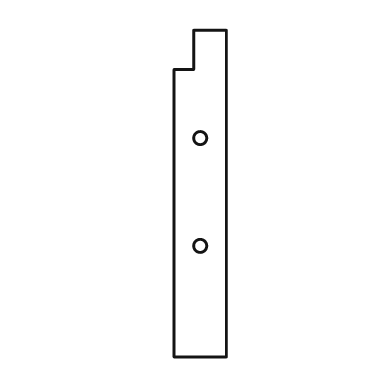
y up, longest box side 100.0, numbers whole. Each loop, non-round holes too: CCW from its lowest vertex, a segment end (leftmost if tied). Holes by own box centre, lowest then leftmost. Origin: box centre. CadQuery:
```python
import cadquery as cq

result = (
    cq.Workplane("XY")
    .moveTo(-8.0, -50.0)
    .lineTo(8.0, -50.0)
    .lineTo(8.0, 50.0)
    .lineTo(-2.0, 50.0)
    .lineTo(-2.0, 38.0)
    .lineTo(-8.0, 38.0)
    .close()
    .moveTo(0.0, -16.0)
    .circle(2.0)
    .moveTo(0.0, 17.0)
    .circle(2.0)
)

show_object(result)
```